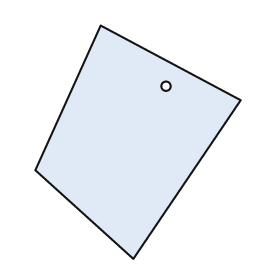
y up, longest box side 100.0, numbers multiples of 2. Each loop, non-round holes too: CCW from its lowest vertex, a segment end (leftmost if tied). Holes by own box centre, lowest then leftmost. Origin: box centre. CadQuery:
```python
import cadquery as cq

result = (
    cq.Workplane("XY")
    .moveTo(-2.0, -50.0)
    .lineTo(44.0, 18.0)
    .lineTo(-16.0, 50.0)
    .lineTo(-44.0, -12.0)
    .close()
    .moveTo(12.0, 24.0)
    .circle(2.0)
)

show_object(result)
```